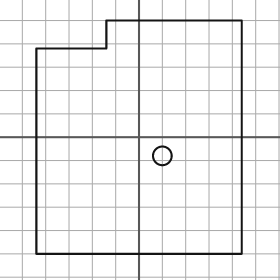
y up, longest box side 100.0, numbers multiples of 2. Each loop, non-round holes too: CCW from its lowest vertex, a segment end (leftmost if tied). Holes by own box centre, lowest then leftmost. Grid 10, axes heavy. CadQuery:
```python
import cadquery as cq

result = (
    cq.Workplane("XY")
    .moveTo(-44.0, -50.0)
    .lineTo(44.0, -50.0)
    .lineTo(44.0, 50.0)
    .lineTo(-14.0, 50.0)
    .lineTo(-14.0, 38.0)
    .lineTo(-44.0, 38.0)
    .close()
    .moveTo(10.0, -8.0)
    .circle(4.0)
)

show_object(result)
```